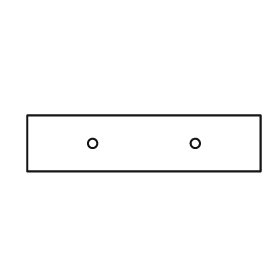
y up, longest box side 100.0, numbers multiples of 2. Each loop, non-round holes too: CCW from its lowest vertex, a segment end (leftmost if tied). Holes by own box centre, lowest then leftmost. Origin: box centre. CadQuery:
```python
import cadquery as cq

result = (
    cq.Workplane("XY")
    .moveTo(-50.0, -12.0)
    .lineTo(50.0, -12.0)
    .lineTo(50.0, 12.0)
    .lineTo(-50.0, 12.0)
    .close()
    .moveTo(-22.0, 0.0)
    .circle(2.0)
    .moveTo(22.0, 0.0)
    .circle(2.0)
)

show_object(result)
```